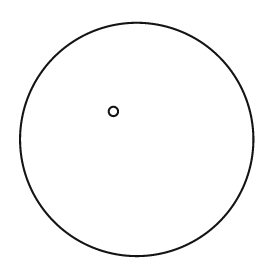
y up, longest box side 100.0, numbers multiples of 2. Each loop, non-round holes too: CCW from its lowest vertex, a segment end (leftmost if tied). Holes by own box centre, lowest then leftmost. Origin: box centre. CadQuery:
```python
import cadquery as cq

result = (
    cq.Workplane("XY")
    .moveTo(0.0, 0.0)
    .circle(50.0)
    .moveTo(-10.0, 12.0)
    .circle(2.0)
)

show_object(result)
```